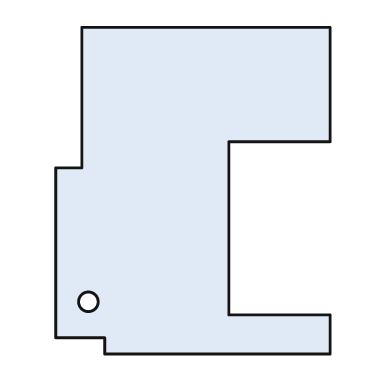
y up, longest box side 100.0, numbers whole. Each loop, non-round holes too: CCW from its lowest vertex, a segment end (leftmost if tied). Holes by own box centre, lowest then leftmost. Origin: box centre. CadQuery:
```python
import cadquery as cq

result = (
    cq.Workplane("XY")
    .moveTo(-27.0, -50.0)
    .lineTo(42.0, -50.0)
    .lineTo(42.0, -38.0)
    .lineTo(11.0, -38.0)
    .lineTo(11.0, 15.0)
    .lineTo(42.0, 15.0)
    .lineTo(42.0, 50.0)
    .lineTo(-34.0, 50.0)
    .lineTo(-34.0, 7.0)
    .lineTo(-42.0, 7.0)
    .lineTo(-42.0, -45.0)
    .lineTo(-27.0, -45.0)
    .close()
    .moveTo(-32.0, -34.0)
    .circle(3.0)
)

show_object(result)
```